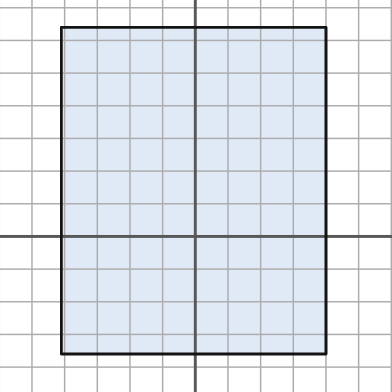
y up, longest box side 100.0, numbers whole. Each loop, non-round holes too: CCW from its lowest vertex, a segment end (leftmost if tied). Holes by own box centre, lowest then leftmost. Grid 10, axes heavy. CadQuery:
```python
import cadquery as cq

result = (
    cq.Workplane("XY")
    .moveTo(-41.0, -36.0)
    .lineTo(40.0, -36.0)
    .lineTo(40.0, 64.0)
    .lineTo(-41.0, 64.0)
    .close()
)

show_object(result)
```